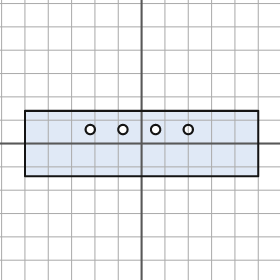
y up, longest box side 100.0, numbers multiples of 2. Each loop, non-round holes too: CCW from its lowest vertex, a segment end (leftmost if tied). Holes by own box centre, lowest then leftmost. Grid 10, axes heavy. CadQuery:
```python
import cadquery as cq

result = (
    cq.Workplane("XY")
    .moveTo(-50.0, -14.0)
    .lineTo(50.0, -14.0)
    .lineTo(50.0, 14.0)
    .lineTo(-50.0, 14.0)
    .close()
    .moveTo(-22.0, 6.0)
    .circle(2.0)
    .moveTo(-8.0, 6.0)
    .circle(2.0)
    .moveTo(6.0, 6.0)
    .circle(2.0)
    .moveTo(20.0, 6.0)
    .circle(2.0)
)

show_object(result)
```